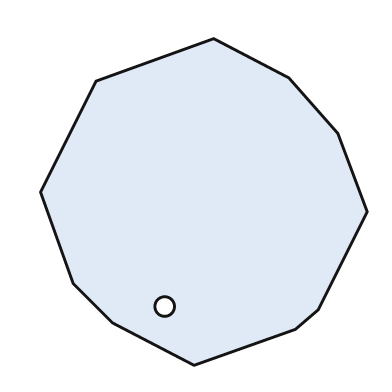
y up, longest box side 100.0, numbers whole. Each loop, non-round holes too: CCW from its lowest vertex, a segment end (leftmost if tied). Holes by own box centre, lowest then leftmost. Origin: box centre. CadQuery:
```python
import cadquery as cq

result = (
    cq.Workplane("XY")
    .moveTo(-3.0, -50.0)
    .lineTo(28.0, -39.0)
    .lineTo(35.0, -33.0)
    .lineTo(50.0, -3.0)
    .lineTo(41.0, 21.0)
    .lineTo(26.0, 38.0)
    .lineTo(3.0, 50.0)
    .lineTo(-33.0, 37.0)
    .lineTo(-50.0, 3.0)
    .lineTo(-40.0, -25.0)
    .lineTo(-28.0, -37.0)
    .close()
    .moveTo(-12.0, -32.0)
    .circle(3.0)
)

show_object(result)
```